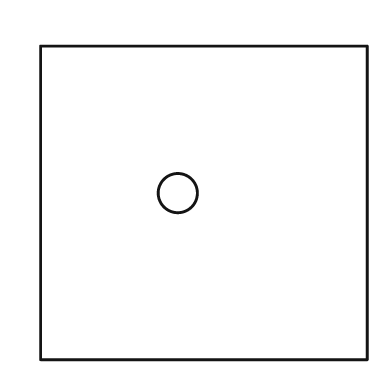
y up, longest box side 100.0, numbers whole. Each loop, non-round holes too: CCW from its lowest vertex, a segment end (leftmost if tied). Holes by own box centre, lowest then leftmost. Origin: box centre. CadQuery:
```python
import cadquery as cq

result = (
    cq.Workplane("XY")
    .moveTo(-50.0, -48.0)
    .lineTo(50.0, -48.0)
    .lineTo(50.0, 48.0)
    .lineTo(-50.0, 48.0)
    .close()
    .moveTo(-8.0, 3.0)
    .circle(6.0)
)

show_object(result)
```